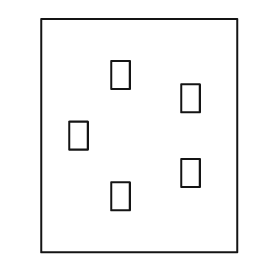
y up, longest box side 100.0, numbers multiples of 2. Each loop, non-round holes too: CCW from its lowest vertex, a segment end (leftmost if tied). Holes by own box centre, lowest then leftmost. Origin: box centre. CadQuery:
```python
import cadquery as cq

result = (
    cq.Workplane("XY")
    .moveTo(-42.0, -50.0)
    .lineTo(42.0, -50.0)
    .lineTo(42.0, 50.0)
    .lineTo(-42.0, 50.0)
    .close()
    .moveTo(-12.0, -32.0)
    .lineTo(-4.0, -32.0)
    .lineTo(-4.0, -20.0)
    .lineTo(-12.0, -20.0)
    .close()
    .moveTo(18.0, -22.0)
    .lineTo(26.0, -22.0)
    .lineTo(26.0, -10.0)
    .lineTo(18.0, -10.0)
    .close()
    .moveTo(-30.0, -6.0)
    .lineTo(-22.0, -6.0)
    .lineTo(-22.0, 6.0)
    .lineTo(-30.0, 6.0)
    .close()
    .moveTo(18.0, 10.0)
    .lineTo(26.0, 10.0)
    .lineTo(26.0, 22.0)
    .lineTo(18.0, 22.0)
    .close()
    .moveTo(-12.0, 20.0)
    .lineTo(-4.0, 20.0)
    .lineTo(-4.0, 32.0)
    .lineTo(-12.0, 32.0)
    .close()
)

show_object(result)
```